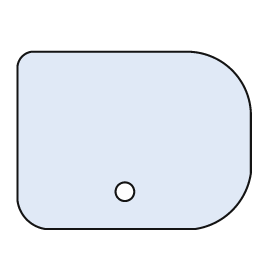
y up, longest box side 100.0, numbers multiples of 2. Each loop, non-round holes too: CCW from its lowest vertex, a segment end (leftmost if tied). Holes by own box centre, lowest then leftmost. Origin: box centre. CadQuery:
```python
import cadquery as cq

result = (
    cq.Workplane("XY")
    .moveTo(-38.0, -38.0)
    .lineTo(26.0, -38.0)
    .threePointArc((42.0, -30.0), (50.0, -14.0))
    .lineTo(50.0, 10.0)
    .threePointArc((42.0, 30.0), (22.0, 38.0))
    .lineTo(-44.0, 38.0)
    .threePointArc((-48.0, 36.0), (-50.0, 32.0))
    .lineTo(-50.0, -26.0)
    .threePointArc((-46.0, -34.0), (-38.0, -38.0))
    .close()
    .moveTo(-4.0, -22.0)
    .circle(4.0)
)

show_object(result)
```